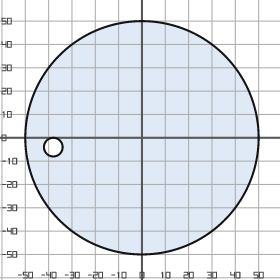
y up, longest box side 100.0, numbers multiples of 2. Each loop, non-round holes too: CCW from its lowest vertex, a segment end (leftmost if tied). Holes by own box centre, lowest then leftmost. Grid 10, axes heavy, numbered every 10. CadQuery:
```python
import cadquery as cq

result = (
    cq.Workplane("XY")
    .moveTo(0.0, 0.0)
    .circle(50.0)
    .moveTo(-38.0, -4.0)
    .circle(4.0)
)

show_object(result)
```